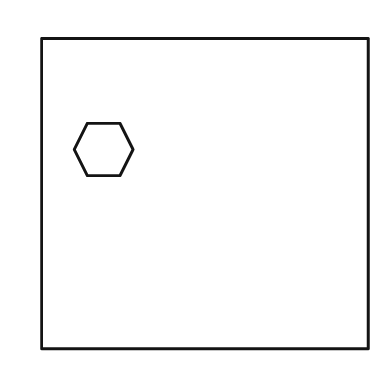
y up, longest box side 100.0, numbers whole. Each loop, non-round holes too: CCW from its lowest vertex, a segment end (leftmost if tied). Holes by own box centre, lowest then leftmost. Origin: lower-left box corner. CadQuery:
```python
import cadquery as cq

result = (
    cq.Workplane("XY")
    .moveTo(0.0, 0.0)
    .lineTo(100.0, 0.0)
    .lineTo(100.0, 95.0)
    .lineTo(0.0, 95.0)
    .close()
    .moveTo(14.0, 53.0)
    .lineTo(24.0, 53.0)
    .lineTo(28.0, 61.0)
    .lineTo(24.0, 69.0)
    .lineTo(14.0, 69.0)
    .lineTo(10.0, 61.0)
    .close()
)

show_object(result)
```